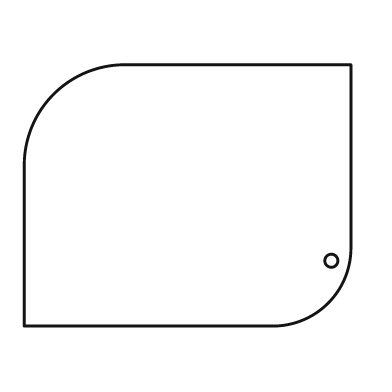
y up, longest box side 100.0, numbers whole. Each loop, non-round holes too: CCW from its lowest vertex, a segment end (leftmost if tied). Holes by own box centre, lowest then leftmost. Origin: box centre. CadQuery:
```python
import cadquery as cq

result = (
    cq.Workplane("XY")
    .moveTo(-50.0, -40.0)
    .lineTo(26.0, -40.0)
    .threePointArc((43.0, -33.0), (50.0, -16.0))
    .lineTo(50.0, 40.0)
    .lineTo(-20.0, 40.0)
    .threePointArc((-41.0, 31.0), (-50.0, 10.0))
    .close()
    .moveTo(44.0, -20.0)
    .circle(2.0)
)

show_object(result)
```